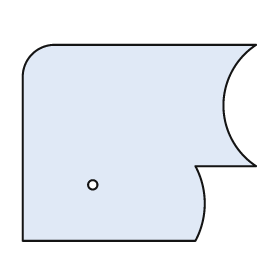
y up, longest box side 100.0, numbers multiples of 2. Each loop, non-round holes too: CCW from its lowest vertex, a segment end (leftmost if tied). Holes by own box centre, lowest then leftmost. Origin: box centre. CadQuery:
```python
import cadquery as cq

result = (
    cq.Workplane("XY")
    .moveTo(-50.0, -42.0)
    .lineTo(24.0, -42.0)
    .threePointArc((28.0, -26.0), (24.0, -10.0))
    .lineTo(50.0, -10.0)
    .threePointArc((36.0, 16.0), (50.0, 42.0))
    .lineTo(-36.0, 42.0)
    .threePointArc((-46.0, 38.0), (-50.0, 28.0))
    .close()
    .moveTo(-20.0, -18.0)
    .circle(2.0)
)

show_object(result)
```